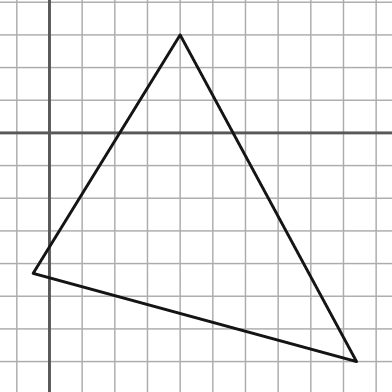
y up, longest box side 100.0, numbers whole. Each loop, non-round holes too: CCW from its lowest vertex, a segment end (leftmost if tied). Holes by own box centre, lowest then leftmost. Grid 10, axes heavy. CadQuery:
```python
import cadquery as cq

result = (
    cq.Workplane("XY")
    .moveTo(94.0, -70.0)
    .lineTo(40.0, 30.0)
    .lineTo(-5.0, -43.0)
    .close()
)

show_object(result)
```